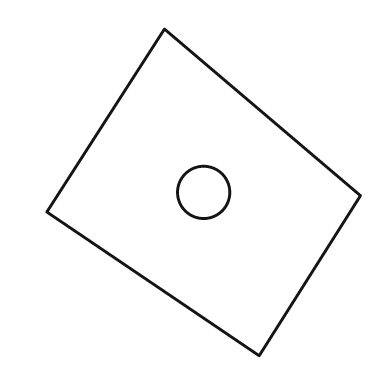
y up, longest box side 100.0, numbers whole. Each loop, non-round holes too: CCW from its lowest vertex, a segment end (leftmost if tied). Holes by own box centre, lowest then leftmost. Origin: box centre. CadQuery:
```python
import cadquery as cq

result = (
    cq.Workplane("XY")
    .moveTo(17.0, -50.0)
    .lineTo(48.0, -1.0)
    .lineTo(-12.0, 50.0)
    .lineTo(-48.0, -6.0)
    .close()
    .moveTo(0.0, 0.0)
    .circle(8.0)
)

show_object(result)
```